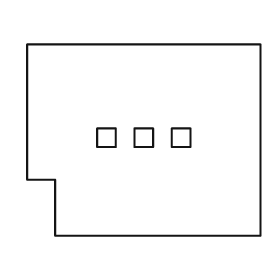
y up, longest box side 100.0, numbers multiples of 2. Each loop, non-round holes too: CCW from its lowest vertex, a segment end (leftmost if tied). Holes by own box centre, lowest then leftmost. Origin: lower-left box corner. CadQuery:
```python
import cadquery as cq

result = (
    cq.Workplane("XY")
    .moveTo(12.0, 0.0)
    .lineTo(100.0, 0.0)
    .lineTo(100.0, 82.0)
    .lineTo(0.0, 82.0)
    .lineTo(0.0, 24.0)
    .lineTo(12.0, 24.0)
    .close()
    .moveTo(30.0, 38.0)
    .lineTo(38.0, 38.0)
    .lineTo(38.0, 46.0)
    .lineTo(30.0, 46.0)
    .close()
    .moveTo(46.0, 38.0)
    .lineTo(54.0, 38.0)
    .lineTo(54.0, 46.0)
    .lineTo(46.0, 46.0)
    .close()
    .moveTo(62.0, 38.0)
    .lineTo(70.0, 38.0)
    .lineTo(70.0, 46.0)
    .lineTo(62.0, 46.0)
    .close()
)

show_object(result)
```